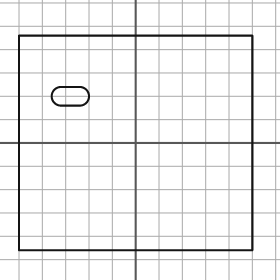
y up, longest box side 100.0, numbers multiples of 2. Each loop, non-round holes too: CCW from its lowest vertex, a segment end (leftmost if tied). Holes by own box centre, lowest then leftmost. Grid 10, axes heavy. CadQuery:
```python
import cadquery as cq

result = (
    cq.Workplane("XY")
    .moveTo(-50.0, -46.0)
    .lineTo(50.0, -46.0)
    .lineTo(50.0, 46.0)
    .lineTo(-50.0, 46.0)
    .close()
    .moveTo(-32.0, 16.0)
    .lineTo(-24.0, 16.0)
    .threePointArc((-20.0, 20.0), (-24.0, 24.0))
    .lineTo(-32.0, 24.0)
    .threePointArc((-36.0, 20.0), (-32.0, 16.0))
    .close()
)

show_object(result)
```